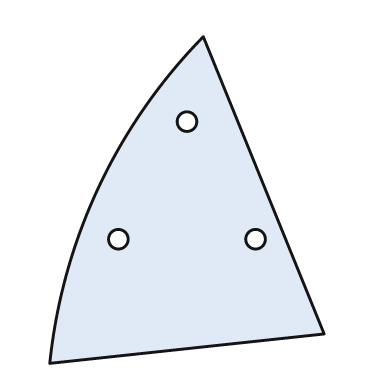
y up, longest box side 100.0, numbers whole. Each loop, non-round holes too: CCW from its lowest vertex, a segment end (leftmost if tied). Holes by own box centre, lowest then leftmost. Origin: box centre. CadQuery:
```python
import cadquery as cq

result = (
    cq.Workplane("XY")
    .moveTo(-42.0, -50.0)
    .lineTo(42.0, -41.0)
    .lineTo(5.0, 50.0)
    .threePointArc((-27.0, 4.0), (-42.0, -50.0))
    .close()
    .moveTo(-21.0, -12.0)
    .circle(3.0)
    .moveTo(21.0, -12.0)
    .circle(3.0)
    .moveTo(0.0, 24.0)
    .circle(3.0)
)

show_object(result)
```